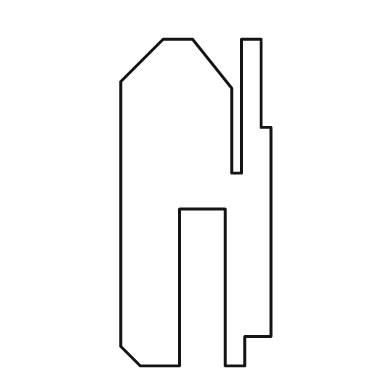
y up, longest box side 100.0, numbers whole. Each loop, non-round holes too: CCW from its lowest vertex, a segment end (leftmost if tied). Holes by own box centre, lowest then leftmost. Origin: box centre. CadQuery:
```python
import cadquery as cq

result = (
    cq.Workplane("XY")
    .moveTo(-17.0, -50.0)
    .lineTo(-5.0, -50.0)
    .lineTo(-5.0, -2.0)
    .lineTo(9.0, -2.0)
    .lineTo(9.0, -50.0)
    .lineTo(15.0, -50.0)
    .lineTo(15.0, -41.0)
    .lineTo(23.0, -41.0)
    .lineTo(23.0, 23.0)
    .lineTo(20.0, 23.0)
    .lineTo(20.0, 50.0)
    .lineTo(14.0, 50.0)
    .lineTo(14.0, 9.0)
    .lineTo(11.0, 9.0)
    .lineTo(11.0, 35.0)
    .lineTo(-1.0, 50.0)
    .lineTo(-10.0, 50.0)
    .lineTo(-23.0, 37.0)
    .lineTo(-23.0, -44.0)
    .close()
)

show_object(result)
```